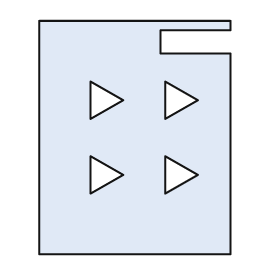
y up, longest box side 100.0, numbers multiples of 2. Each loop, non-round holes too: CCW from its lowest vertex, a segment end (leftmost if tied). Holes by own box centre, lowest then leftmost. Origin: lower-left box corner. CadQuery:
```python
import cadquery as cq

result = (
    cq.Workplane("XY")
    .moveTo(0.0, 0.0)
    .lineTo(82.0, 0.0)
    .lineTo(82.0, 86.0)
    .lineTo(52.0, 86.0)
    .lineTo(52.0, 96.0)
    .lineTo(82.0, 96.0)
    .lineTo(82.0, 100.0)
    .lineTo(0.0, 100.0)
    .close()
    .moveTo(22.0, 26.0)
    .lineTo(36.0, 34.0)
    .lineTo(22.0, 42.0)
    .close()
    .moveTo(54.0, 26.0)
    .lineTo(68.0, 34.0)
    .lineTo(54.0, 42.0)
    .close()
    .moveTo(22.0, 58.0)
    .lineTo(36.0, 66.0)
    .lineTo(22.0, 74.0)
    .close()
    .moveTo(54.0, 58.0)
    .lineTo(68.0, 66.0)
    .lineTo(54.0, 74.0)
    .close()
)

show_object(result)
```